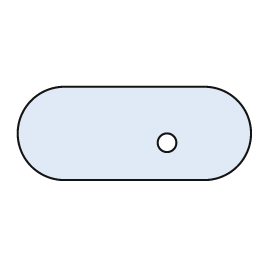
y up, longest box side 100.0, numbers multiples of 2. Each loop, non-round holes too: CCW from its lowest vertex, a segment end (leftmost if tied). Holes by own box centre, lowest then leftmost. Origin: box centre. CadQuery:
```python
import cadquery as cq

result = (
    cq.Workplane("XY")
    .moveTo(-30.0, -20.0)
    .lineTo(30.0, -20.0)
    .threePointArc((50.0, 0.0), (30.0, 20.0))
    .lineTo(-30.0, 20.0)
    .threePointArc((-50.0, 0.0), (-30.0, -20.0))
    .close()
    .moveTo(14.0, -4.0)
    .circle(4.0)
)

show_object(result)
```